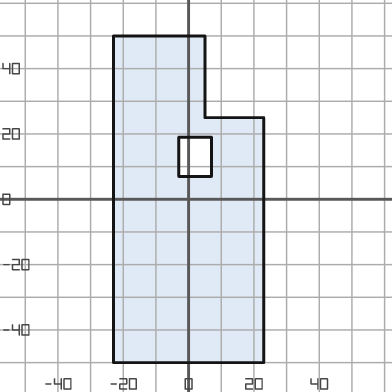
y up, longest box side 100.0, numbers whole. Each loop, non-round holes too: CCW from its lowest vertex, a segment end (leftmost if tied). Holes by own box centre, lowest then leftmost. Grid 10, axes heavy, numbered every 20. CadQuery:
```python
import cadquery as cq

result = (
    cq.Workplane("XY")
    .moveTo(-23.0, -50.0)
    .lineTo(23.0, -50.0)
    .lineTo(23.0, 25.0)
    .lineTo(5.0, 25.0)
    .lineTo(5.0, 50.0)
    .lineTo(-23.0, 50.0)
    .close()
    .moveTo(-3.0, 7.0)
    .lineTo(7.0, 7.0)
    .lineTo(7.0, 19.0)
    .lineTo(-3.0, 19.0)
    .close()
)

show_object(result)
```